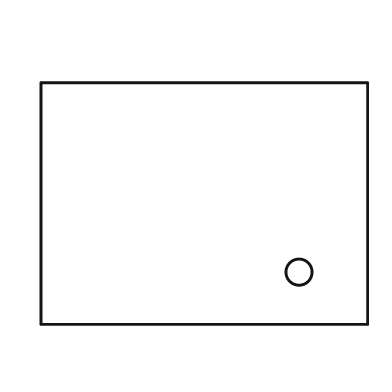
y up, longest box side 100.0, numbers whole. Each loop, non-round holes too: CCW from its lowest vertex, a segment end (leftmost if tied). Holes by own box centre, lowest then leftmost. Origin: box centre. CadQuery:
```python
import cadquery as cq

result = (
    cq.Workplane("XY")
    .moveTo(-50.0, -37.0)
    .lineTo(50.0, -37.0)
    .lineTo(50.0, 37.0)
    .lineTo(-50.0, 37.0)
    .close()
    .moveTo(29.0, -21.0)
    .circle(4.0)
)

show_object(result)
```